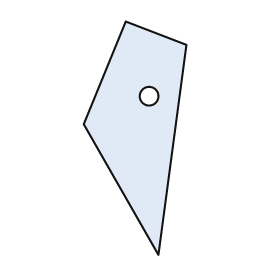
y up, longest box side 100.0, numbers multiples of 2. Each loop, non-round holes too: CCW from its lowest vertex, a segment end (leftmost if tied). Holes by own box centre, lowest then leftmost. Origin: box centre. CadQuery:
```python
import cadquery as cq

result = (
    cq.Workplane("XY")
    .moveTo(10.0, -50.0)
    .lineTo(22.0, 40.0)
    .lineTo(-4.0, 50.0)
    .lineTo(-22.0, 6.0)
    .close()
    .moveTo(6.0, 18.0)
    .circle(4.0)
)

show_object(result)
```